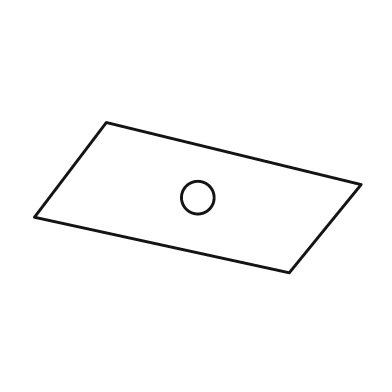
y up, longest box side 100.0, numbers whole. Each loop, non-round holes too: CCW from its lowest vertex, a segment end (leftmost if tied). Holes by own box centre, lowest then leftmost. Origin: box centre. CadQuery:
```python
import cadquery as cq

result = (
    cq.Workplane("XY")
    .moveTo(28.0, -23.0)
    .lineTo(50.0, 4.0)
    .lineTo(-28.0, 23.0)
    .lineTo(-50.0, -6.0)
    .close()
    .moveTo(0.0, 0.0)
    .circle(5.0)
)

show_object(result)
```